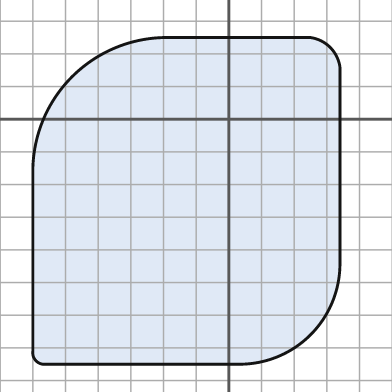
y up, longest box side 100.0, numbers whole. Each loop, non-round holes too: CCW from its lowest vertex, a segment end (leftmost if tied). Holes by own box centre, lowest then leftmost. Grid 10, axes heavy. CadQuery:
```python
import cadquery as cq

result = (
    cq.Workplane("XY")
    .moveTo(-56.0, -75.0)
    .lineTo(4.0, -75.0)
    .threePointArc((25.0, -66.0), (34.0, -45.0))
    .lineTo(34.0, 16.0)
    .threePointArc((31.0, 22.0), (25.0, 25.0))
    .lineTo(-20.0, 25.0)
    .threePointArc((-48.0, 13.0), (-60.0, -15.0))
    .lineTo(-60.0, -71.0)
    .threePointArc((-59.0, -74.0), (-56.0, -75.0))
    .close()
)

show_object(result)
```